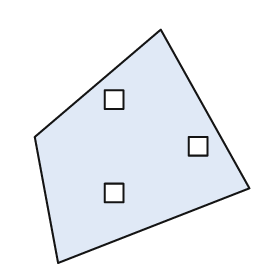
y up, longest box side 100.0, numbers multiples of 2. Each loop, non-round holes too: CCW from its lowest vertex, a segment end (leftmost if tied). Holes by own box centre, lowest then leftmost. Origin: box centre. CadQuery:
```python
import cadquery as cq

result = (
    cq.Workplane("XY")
    .moveTo(-36.0, -50.0)
    .lineTo(46.0, -18.0)
    .lineTo(8.0, 50.0)
    .lineTo(-46.0, 4.0)
    .close()
    .moveTo(-16.0, -24.0)
    .lineTo(-8.0, -24.0)
    .lineTo(-8.0, -16.0)
    .lineTo(-16.0, -16.0)
    .close()
    .moveTo(20.0, -4.0)
    .lineTo(28.0, -4.0)
    .lineTo(28.0, 4.0)
    .lineTo(20.0, 4.0)
    .close()
    .moveTo(-16.0, 16.0)
    .lineTo(-8.0, 16.0)
    .lineTo(-8.0, 24.0)
    .lineTo(-16.0, 24.0)
    .close()
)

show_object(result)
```